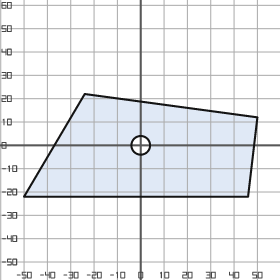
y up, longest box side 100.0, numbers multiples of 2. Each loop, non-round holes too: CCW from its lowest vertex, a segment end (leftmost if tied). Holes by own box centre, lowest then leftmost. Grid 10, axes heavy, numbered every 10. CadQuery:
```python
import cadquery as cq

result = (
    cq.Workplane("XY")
    .moveTo(-50.0, -22.0)
    .lineTo(46.0, -22.0)
    .lineTo(50.0, 12.0)
    .lineTo(-24.0, 22.0)
    .close()
    .moveTo(0.0, 0.0)
    .circle(4.0)
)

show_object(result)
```